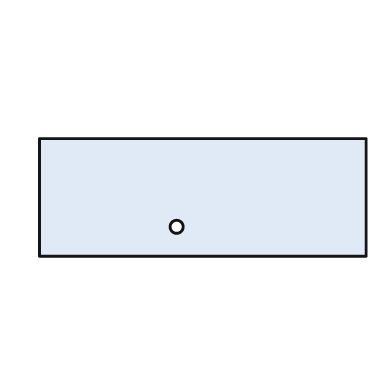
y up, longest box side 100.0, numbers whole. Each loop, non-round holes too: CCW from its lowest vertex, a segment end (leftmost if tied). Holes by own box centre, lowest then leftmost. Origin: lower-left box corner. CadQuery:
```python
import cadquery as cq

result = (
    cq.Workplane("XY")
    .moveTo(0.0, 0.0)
    .lineTo(100.0, 0.0)
    .lineTo(100.0, 36.0)
    .lineTo(0.0, 36.0)
    .close()
    .moveTo(42.0, 9.0)
    .circle(2.0)
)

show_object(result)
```